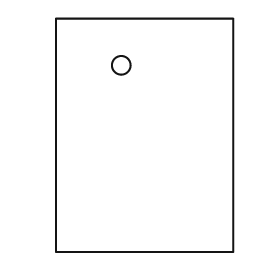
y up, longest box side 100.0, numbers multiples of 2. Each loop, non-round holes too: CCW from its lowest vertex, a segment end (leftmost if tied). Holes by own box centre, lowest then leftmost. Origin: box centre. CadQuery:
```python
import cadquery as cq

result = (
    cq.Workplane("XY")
    .moveTo(-38.0, -50.0)
    .lineTo(38.0, -50.0)
    .lineTo(38.0, 50.0)
    .lineTo(-38.0, 50.0)
    .close()
    .moveTo(-10.0, 30.0)
    .circle(4.0)
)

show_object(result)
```